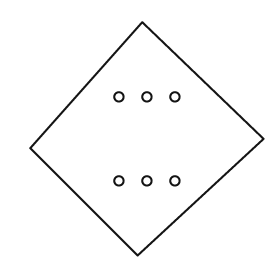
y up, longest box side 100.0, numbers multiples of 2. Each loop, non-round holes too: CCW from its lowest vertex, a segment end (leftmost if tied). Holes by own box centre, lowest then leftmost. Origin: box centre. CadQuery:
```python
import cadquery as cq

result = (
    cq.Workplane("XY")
    .moveTo(-4.0, -50.0)
    .lineTo(50.0, 0.0)
    .lineTo(-2.0, 50.0)
    .lineTo(-50.0, -4.0)
    .close()
    .moveTo(-12.0, -18.0)
    .circle(2.0)
    .moveTo(0.0, -18.0)
    .circle(2.0)
    .moveTo(12.0, -18.0)
    .circle(2.0)
    .moveTo(-12.0, 18.0)
    .circle(2.0)
    .moveTo(0.0, 18.0)
    .circle(2.0)
    .moveTo(12.0, 18.0)
    .circle(2.0)
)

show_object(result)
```